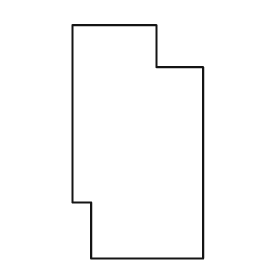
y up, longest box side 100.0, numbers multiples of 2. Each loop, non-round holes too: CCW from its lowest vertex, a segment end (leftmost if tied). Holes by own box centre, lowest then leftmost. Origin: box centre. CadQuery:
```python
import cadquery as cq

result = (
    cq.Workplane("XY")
    .moveTo(-20.0, -50.0)
    .lineTo(28.0, -50.0)
    .lineTo(28.0, 32.0)
    .lineTo(8.0, 32.0)
    .lineTo(8.0, 50.0)
    .lineTo(-28.0, 50.0)
    .lineTo(-28.0, -26.0)
    .lineTo(-20.0, -26.0)
    .close()
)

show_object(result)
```